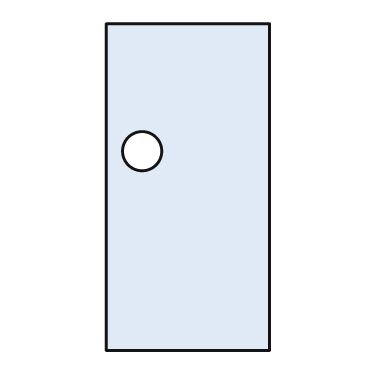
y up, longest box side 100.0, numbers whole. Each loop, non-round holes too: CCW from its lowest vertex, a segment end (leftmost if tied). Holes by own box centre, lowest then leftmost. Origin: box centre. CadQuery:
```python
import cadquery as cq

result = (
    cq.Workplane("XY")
    .moveTo(-25.0, -50.0)
    .lineTo(25.0, -50.0)
    .lineTo(25.0, 50.0)
    .lineTo(-25.0, 50.0)
    .close()
    .moveTo(-14.0, 11.0)
    .circle(6.0)
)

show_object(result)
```